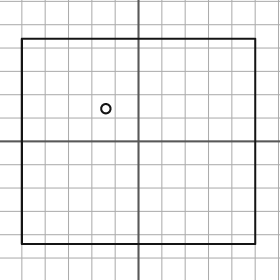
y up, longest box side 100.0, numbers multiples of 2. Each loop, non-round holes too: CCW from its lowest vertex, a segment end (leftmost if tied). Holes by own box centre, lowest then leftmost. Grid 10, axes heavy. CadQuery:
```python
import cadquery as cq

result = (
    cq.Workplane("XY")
    .moveTo(-50.0, -44.0)
    .lineTo(50.0, -44.0)
    .lineTo(50.0, 44.0)
    .lineTo(-50.0, 44.0)
    .close()
    .moveTo(-14.0, 14.0)
    .circle(2.0)
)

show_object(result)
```